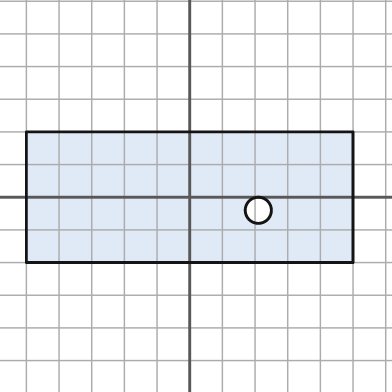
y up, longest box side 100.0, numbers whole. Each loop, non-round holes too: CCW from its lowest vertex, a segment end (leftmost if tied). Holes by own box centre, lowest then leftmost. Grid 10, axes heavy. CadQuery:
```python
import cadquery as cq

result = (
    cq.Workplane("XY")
    .moveTo(-50.0, -20.0)
    .lineTo(50.0, -20.0)
    .lineTo(50.0, 20.0)
    .lineTo(-50.0, 20.0)
    .close()
    .moveTo(21.0, -4.0)
    .circle(4.0)
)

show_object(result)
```